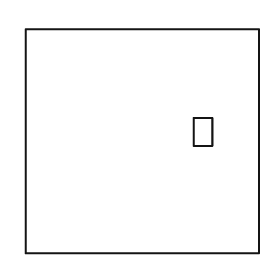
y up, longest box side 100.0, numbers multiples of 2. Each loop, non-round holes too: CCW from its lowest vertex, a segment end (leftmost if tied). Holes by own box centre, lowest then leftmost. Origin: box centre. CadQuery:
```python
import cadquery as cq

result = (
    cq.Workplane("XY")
    .moveTo(-50.0, -48.0)
    .lineTo(50.0, -48.0)
    .lineTo(50.0, 48.0)
    .lineTo(-50.0, 48.0)
    .close()
    .moveTo(22.0, -2.0)
    .lineTo(30.0, -2.0)
    .lineTo(30.0, 10.0)
    .lineTo(22.0, 10.0)
    .close()
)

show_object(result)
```